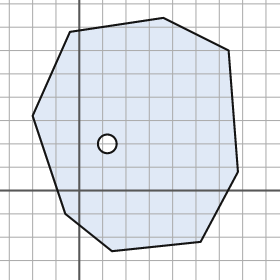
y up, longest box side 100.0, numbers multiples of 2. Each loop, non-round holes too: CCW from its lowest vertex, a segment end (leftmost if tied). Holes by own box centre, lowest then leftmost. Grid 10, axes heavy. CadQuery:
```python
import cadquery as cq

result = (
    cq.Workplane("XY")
    .moveTo(14.0, -26.0)
    .lineTo(52.0, -22.0)
    .lineTo(68.0, 8.0)
    .lineTo(64.0, 60.0)
    .lineTo(36.0, 74.0)
    .lineTo(-4.0, 68.0)
    .lineTo(-20.0, 32.0)
    .lineTo(-6.0, -10.0)
    .close()
    .moveTo(12.0, 20.0)
    .circle(4.0)
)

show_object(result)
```